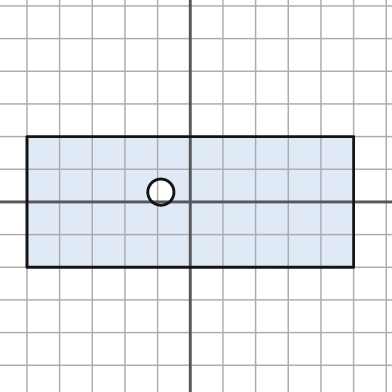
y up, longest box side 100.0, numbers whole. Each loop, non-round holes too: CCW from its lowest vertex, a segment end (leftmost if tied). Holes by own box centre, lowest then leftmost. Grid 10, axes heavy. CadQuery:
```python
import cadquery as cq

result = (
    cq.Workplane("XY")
    .moveTo(-50.0, -20.0)
    .lineTo(50.0, -20.0)
    .lineTo(50.0, 20.0)
    .lineTo(-50.0, 20.0)
    .close()
    .moveTo(-9.0, 3.0)
    .circle(4.0)
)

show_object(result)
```